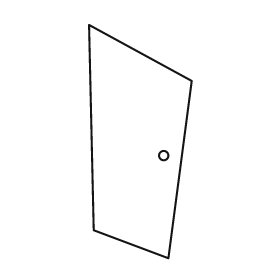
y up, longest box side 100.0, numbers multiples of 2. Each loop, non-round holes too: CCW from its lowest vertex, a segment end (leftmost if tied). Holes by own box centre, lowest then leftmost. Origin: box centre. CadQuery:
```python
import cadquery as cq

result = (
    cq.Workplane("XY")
    .moveTo(12.0, -50.0)
    .lineTo(22.0, 26.0)
    .lineTo(-22.0, 50.0)
    .lineTo(-20.0, -38.0)
    .close()
    .moveTo(10.0, -6.0)
    .circle(2.0)
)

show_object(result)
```